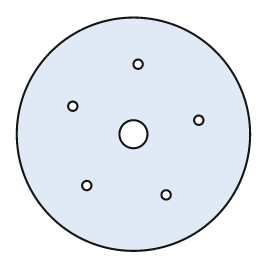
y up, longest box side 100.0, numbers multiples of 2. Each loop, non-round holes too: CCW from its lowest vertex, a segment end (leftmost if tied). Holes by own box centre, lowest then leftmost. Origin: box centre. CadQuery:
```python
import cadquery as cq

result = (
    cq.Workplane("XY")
    .moveTo(0.0, 0.0)
    .circle(50.0)
    .moveTo(14.0, -26.0)
    .circle(2.0)
    .moveTo(-20.0, -22.0)
    .circle(2.0)
    .moveTo(0.0, 0.0)
    .circle(6.0)
    .moveTo(28.0, 6.0)
    .circle(2.0)
    .moveTo(-26.0, 12.0)
    .circle(2.0)
    .moveTo(2.0, 30.0)
    .circle(2.0)
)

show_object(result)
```